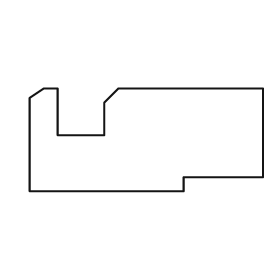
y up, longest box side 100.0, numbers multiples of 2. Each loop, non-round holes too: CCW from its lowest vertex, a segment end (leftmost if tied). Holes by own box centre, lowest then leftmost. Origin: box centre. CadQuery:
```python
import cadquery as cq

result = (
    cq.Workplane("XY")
    .moveTo(-50.0, -22.0)
    .lineTo(16.0, -22.0)
    .lineTo(16.0, -16.0)
    .lineTo(50.0, -16.0)
    .lineTo(50.0, 22.0)
    .lineTo(-12.0, 22.0)
    .lineTo(-18.0, 16.0)
    .lineTo(-18.0, 2.0)
    .lineTo(-38.0, 2.0)
    .lineTo(-38.0, 22.0)
    .lineTo(-44.0, 22.0)
    .lineTo(-50.0, 18.0)
    .close()
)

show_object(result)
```